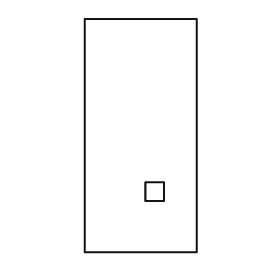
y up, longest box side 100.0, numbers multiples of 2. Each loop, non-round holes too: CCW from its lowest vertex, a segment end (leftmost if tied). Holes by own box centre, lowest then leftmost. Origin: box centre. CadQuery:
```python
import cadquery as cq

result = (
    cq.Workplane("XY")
    .moveTo(-24.0, -50.0)
    .lineTo(24.0, -50.0)
    .lineTo(24.0, 50.0)
    .lineTo(-24.0, 50.0)
    .close()
    .moveTo(2.0, -28.0)
    .lineTo(10.0, -28.0)
    .lineTo(10.0, -20.0)
    .lineTo(2.0, -20.0)
    .close()
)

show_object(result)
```